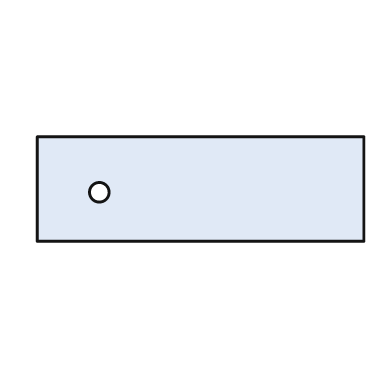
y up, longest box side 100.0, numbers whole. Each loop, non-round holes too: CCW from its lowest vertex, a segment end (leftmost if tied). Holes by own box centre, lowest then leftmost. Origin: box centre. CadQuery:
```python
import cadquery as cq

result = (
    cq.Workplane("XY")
    .moveTo(-50.0, -16.0)
    .lineTo(50.0, -16.0)
    .lineTo(50.0, 16.0)
    .lineTo(-50.0, 16.0)
    .close()
    .moveTo(-31.0, -1.0)
    .circle(3.0)
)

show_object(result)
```